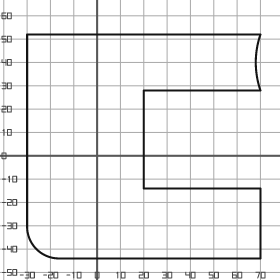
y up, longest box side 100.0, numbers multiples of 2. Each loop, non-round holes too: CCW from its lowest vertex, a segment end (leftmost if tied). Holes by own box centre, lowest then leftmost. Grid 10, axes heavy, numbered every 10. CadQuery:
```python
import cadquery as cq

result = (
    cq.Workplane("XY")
    .moveTo(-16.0, -44.0)
    .lineTo(70.0, -44.0)
    .lineTo(70.0, -14.0)
    .lineTo(20.0, -14.0)
    .lineTo(20.0, 28.0)
    .lineTo(70.0, 28.0)
    .threePointArc((68.0, 40.0), (70.0, 52.0))
    .lineTo(-30.0, 52.0)
    .lineTo(-30.0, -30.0)
    .threePointArc((-26.0, -40.0), (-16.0, -44.0))
    .close()
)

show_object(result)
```